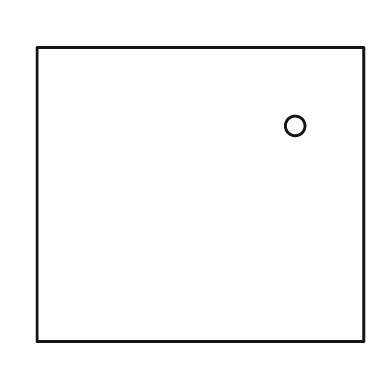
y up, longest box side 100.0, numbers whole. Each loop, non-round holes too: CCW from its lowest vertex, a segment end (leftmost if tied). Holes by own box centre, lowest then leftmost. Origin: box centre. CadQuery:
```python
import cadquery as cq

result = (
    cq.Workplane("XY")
    .moveTo(-50.0, -45.0)
    .lineTo(50.0, -45.0)
    .lineTo(50.0, 45.0)
    .lineTo(-50.0, 45.0)
    .close()
    .moveTo(29.0, 21.0)
    .circle(3.0)
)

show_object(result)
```